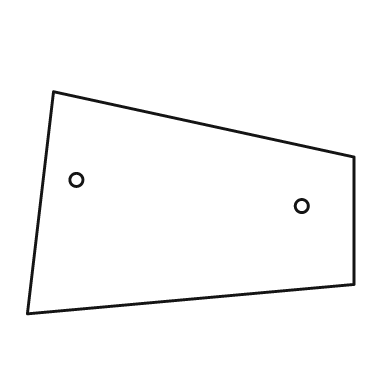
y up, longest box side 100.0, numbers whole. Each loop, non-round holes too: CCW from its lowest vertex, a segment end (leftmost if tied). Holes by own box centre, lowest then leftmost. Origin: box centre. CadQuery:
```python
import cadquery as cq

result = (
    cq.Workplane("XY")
    .moveTo(-50.0, -34.0)
    .lineTo(50.0, -25.0)
    .lineTo(50.0, 14.0)
    .lineTo(-42.0, 34.0)
    .close()
    .moveTo(34.0, -1.0)
    .circle(2.0)
    .moveTo(-35.0, 7.0)
    .circle(2.0)
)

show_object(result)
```